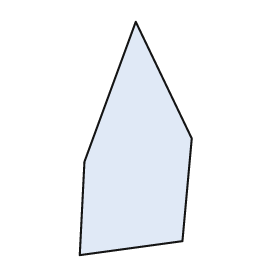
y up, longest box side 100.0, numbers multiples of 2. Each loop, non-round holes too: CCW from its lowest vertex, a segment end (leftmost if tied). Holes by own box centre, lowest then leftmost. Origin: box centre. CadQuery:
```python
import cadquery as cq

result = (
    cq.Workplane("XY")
    .moveTo(-24.0, -50.0)
    .lineTo(20.0, -44.0)
    .lineTo(24.0, 0.0)
    .lineTo(0.0, 50.0)
    .lineTo(-22.0, -10.0)
    .close()
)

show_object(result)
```